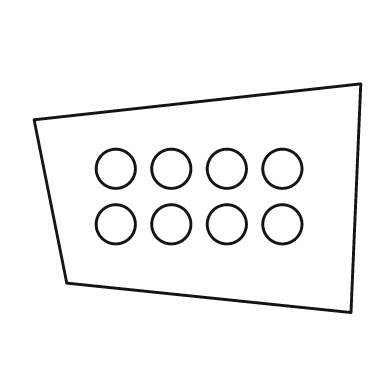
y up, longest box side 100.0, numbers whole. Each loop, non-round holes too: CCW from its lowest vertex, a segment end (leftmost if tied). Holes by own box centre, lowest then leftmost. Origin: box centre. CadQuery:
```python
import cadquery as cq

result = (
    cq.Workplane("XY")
    .moveTo(47.0, -35.0)
    .lineTo(50.0, 35.0)
    .lineTo(-50.0, 24.0)
    .lineTo(-40.0, -26.0)
    .close()
    .moveTo(-25.0, -8.0)
    .circle(6.0)
    .moveTo(-8.0, -8.0)
    .circle(6.0)
    .moveTo(9.0, -8.0)
    .circle(6.0)
    .moveTo(26.0, -8.0)
    .circle(6.0)
    .moveTo(-25.0, 9.0)
    .circle(6.0)
    .moveTo(-8.0, 9.0)
    .circle(6.0)
    .moveTo(9.0, 9.0)
    .circle(6.0)
    .moveTo(26.0, 9.0)
    .circle(6.0)
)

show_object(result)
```